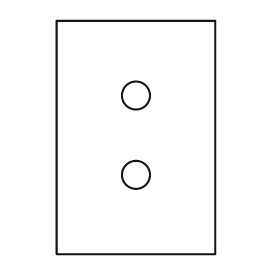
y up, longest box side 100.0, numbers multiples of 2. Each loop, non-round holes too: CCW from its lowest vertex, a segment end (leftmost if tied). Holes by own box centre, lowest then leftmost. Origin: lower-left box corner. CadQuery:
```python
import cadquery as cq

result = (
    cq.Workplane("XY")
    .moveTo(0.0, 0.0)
    .lineTo(68.0, 0.0)
    .lineTo(68.0, 100.0)
    .lineTo(0.0, 100.0)
    .close()
    .moveTo(34.0, 34.0)
    .circle(6.0)
    .moveTo(34.0, 68.0)
    .circle(6.0)
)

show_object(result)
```